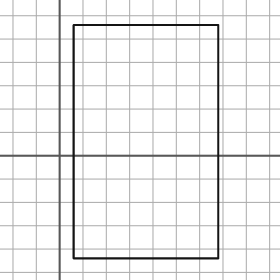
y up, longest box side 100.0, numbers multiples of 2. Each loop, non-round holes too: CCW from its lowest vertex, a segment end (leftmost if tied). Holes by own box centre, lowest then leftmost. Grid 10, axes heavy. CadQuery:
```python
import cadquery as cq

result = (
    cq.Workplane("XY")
    .moveTo(6.0, -44.0)
    .lineTo(68.0, -44.0)
    .lineTo(68.0, 56.0)
    .lineTo(6.0, 56.0)
    .close()
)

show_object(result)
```